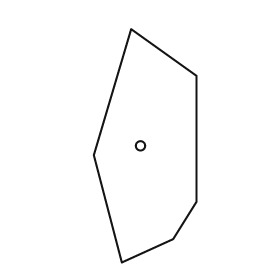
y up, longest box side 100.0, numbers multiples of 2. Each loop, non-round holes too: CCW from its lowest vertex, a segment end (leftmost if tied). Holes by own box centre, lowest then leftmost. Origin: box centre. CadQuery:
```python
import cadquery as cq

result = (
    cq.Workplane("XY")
    .moveTo(-10.0, -50.0)
    .lineTo(12.0, -40.0)
    .lineTo(22.0, -24.0)
    .lineTo(22.0, 30.0)
    .lineTo(-6.0, 50.0)
    .lineTo(-22.0, -4.0)
    .close()
    .moveTo(-2.0, 0.0)
    .circle(2.0)
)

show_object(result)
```